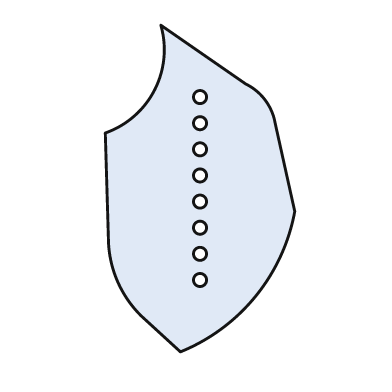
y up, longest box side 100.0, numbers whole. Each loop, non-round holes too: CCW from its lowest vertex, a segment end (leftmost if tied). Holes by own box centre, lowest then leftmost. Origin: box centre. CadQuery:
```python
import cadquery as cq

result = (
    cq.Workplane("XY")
    .moveTo(-6.0, -50.0)
    .threePointArc((17.0, -33.0), (29.0, -7.0))
    .lineTo(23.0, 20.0)
    .threePointArc((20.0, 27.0), (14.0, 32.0))
    .lineTo(-12.0, 50.0)
    .threePointArc((-14.0, 30.0), (-29.0, 17.0))
    .lineTo(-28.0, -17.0)
    .threePointArc((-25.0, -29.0), (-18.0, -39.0))
    .close()
    .moveTo(0.0, -28.0)
    .circle(2.0)
    .moveTo(0.0, -20.0)
    .circle(2.0)
    .moveTo(0.0, -12.0)
    .circle(2.0)
    .moveTo(0.0, -4.0)
    .circle(2.0)
    .moveTo(0.0, 4.0)
    .circle(2.0)
    .moveTo(0.0, 12.0)
    .circle(2.0)
    .moveTo(0.0, 20.0)
    .circle(2.0)
    .moveTo(0.0, 28.0)
    .circle(2.0)
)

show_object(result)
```